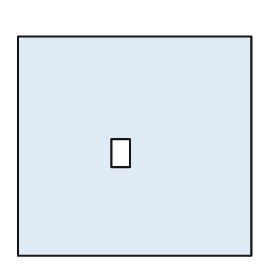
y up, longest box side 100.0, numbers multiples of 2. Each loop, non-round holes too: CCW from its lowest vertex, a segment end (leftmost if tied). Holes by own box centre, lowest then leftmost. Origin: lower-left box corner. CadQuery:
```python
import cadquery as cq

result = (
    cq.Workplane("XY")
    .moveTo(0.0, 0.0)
    .lineTo(100.0, 0.0)
    .lineTo(100.0, 94.0)
    .lineTo(0.0, 94.0)
    .close()
    .moveTo(40.0, 38.0)
    .lineTo(48.0, 38.0)
    .lineTo(48.0, 50.0)
    .lineTo(40.0, 50.0)
    .close()
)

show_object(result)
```